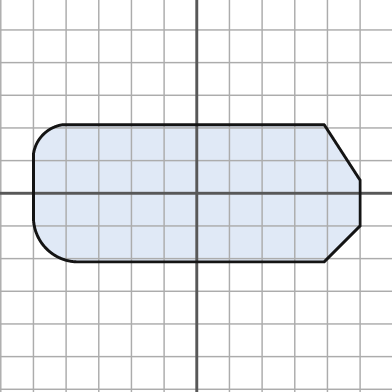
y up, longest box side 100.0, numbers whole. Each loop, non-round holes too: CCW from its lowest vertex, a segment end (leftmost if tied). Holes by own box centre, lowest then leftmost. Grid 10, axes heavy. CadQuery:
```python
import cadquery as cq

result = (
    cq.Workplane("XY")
    .moveTo(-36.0, -21.0)
    .lineTo(39.0, -21.0)
    .lineTo(50.0, -10.0)
    .lineTo(50.0, 4.0)
    .lineTo(39.0, 21.0)
    .lineTo(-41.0, 21.0)
    .threePointArc((-47.0, 18.0), (-50.0, 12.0))
    .lineTo(-50.0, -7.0)
    .threePointArc((-46.0, -17.0), (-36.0, -21.0))
    .close()
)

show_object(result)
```